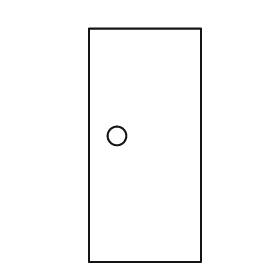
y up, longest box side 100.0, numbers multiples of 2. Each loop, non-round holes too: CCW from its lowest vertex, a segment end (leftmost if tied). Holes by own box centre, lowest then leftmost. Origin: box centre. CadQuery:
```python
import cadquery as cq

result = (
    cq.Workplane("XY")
    .moveTo(-24.0, -50.0)
    .lineTo(24.0, -50.0)
    .lineTo(24.0, 50.0)
    .lineTo(-24.0, 50.0)
    .close()
    .moveTo(-12.0, 4.0)
    .circle(4.0)
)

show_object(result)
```